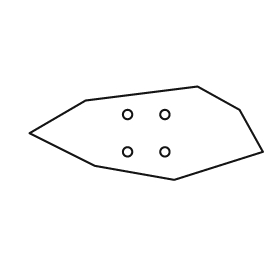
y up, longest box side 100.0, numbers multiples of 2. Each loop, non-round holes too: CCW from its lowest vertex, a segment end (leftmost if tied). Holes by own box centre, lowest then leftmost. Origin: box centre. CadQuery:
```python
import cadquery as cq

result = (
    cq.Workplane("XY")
    .moveTo(12.0, -20.0)
    .lineTo(50.0, -8.0)
    .lineTo(40.0, 10.0)
    .lineTo(22.0, 20.0)
    .lineTo(-26.0, 14.0)
    .lineTo(-50.0, 0.0)
    .lineTo(-22.0, -14.0)
    .close()
    .moveTo(-8.0, -8.0)
    .circle(2.0)
    .moveTo(8.0, -8.0)
    .circle(2.0)
    .moveTo(-8.0, 8.0)
    .circle(2.0)
    .moveTo(8.0, 8.0)
    .circle(2.0)
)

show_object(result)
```